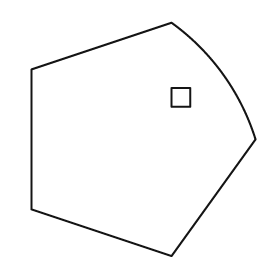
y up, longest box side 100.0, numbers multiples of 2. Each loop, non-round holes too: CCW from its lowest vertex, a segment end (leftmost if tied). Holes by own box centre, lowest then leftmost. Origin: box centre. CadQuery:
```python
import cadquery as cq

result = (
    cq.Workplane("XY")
    .moveTo(12.0, -50.0)
    .lineTo(48.0, 0.0)
    .threePointArc((34.0, 28.0), (12.0, 50.0))
    .lineTo(-48.0, 30.0)
    .lineTo(-48.0, -30.0)
    .close()
    .moveTo(12.0, 14.0)
    .lineTo(20.0, 14.0)
    .lineTo(20.0, 22.0)
    .lineTo(12.0, 22.0)
    .close()
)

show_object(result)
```